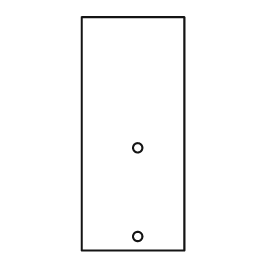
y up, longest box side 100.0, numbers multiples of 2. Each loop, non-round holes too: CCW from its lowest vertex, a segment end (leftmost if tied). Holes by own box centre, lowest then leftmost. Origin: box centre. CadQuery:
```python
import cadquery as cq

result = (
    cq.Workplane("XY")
    .moveTo(-22.0, -50.0)
    .lineTo(22.0, -50.0)
    .lineTo(22.0, 50.0)
    .lineTo(-22.0, 50.0)
    .close()
    .moveTo(2.0, -44.0)
    .circle(2.0)
    .moveTo(2.0, -6.0)
    .circle(2.0)
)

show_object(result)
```